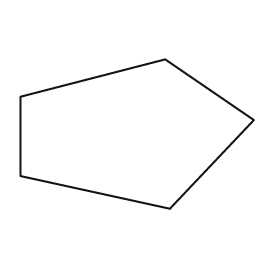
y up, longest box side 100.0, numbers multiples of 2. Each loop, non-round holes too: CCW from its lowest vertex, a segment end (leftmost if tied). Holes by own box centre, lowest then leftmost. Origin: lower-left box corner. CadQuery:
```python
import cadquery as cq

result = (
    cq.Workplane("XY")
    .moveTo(64.0, 0.0)
    .lineTo(100.0, 38.0)
    .lineTo(62.0, 64.0)
    .lineTo(0.0, 48.0)
    .lineTo(0.0, 14.0)
    .close()
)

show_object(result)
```